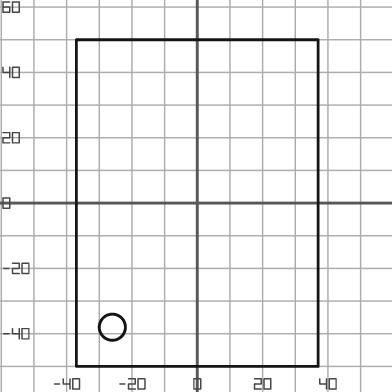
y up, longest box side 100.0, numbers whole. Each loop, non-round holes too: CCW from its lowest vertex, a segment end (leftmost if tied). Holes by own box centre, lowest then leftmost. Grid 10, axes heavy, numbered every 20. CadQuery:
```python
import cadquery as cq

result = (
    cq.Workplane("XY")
    .moveTo(-37.0, -50.0)
    .lineTo(37.0, -50.0)
    .lineTo(37.0, 50.0)
    .lineTo(-37.0, 50.0)
    .close()
    .moveTo(-26.0, -38.0)
    .circle(4.0)
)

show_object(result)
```